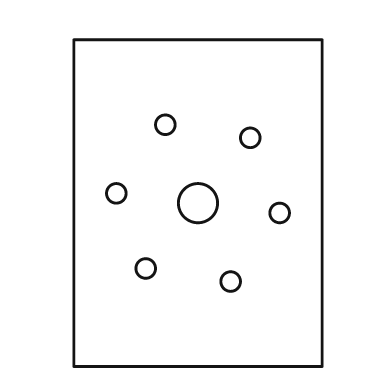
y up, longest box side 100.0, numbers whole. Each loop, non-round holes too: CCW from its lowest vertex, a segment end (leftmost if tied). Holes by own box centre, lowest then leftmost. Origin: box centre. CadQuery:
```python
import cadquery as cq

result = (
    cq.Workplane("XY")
    .moveTo(-38.0, -50.0)
    .lineTo(38.0, -50.0)
    .lineTo(38.0, 50.0)
    .lineTo(-38.0, 50.0)
    .close()
    .moveTo(10.0, -24.0)
    .circle(3.0)
    .moveTo(-16.0, -20.0)
    .circle(3.0)
    .moveTo(25.0, -3.0)
    .circle(3.0)
    .moveTo(0.0, 0.0)
    .circle(6.0)
    .moveTo(-25.0, 3.0)
    .circle(3.0)
    .moveTo(16.0, 20.0)
    .circle(3.0)
    .moveTo(-10.0, 24.0)
    .circle(3.0)
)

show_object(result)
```